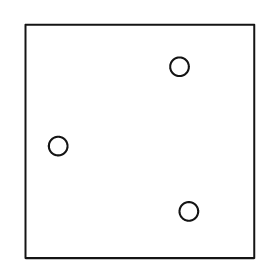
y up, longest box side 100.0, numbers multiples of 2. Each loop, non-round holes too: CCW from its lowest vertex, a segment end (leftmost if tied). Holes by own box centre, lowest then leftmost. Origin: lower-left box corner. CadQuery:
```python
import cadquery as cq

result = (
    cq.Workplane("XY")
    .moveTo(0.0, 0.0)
    .lineTo(98.0, 0.0)
    .lineTo(98.0, 100.0)
    .lineTo(0.0, 100.0)
    .close()
    .moveTo(70.0, 20.0)
    .circle(4.0)
    .moveTo(14.0, 48.0)
    .circle(4.0)
    .moveTo(66.0, 82.0)
    .circle(4.0)
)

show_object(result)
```